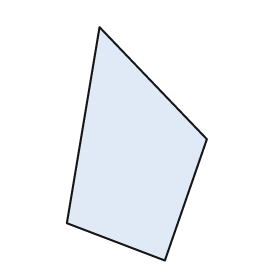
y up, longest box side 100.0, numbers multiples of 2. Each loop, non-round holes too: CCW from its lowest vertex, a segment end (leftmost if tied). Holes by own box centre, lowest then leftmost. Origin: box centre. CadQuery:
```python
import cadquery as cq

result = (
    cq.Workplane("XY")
    .moveTo(12.0, -50.0)
    .lineTo(30.0, 2.0)
    .lineTo(-16.0, 50.0)
    .lineTo(-30.0, -34.0)
    .close()
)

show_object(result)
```